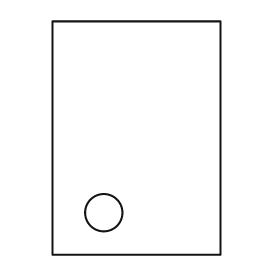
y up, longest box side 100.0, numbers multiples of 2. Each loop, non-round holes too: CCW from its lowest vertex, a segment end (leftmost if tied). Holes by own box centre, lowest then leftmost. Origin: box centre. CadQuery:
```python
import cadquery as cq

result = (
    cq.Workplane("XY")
    .moveTo(-36.0, -50.0)
    .lineTo(36.0, -50.0)
    .lineTo(36.0, 50.0)
    .lineTo(-36.0, 50.0)
    .close()
    .moveTo(-14.0, -32.0)
    .circle(8.0)
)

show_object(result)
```